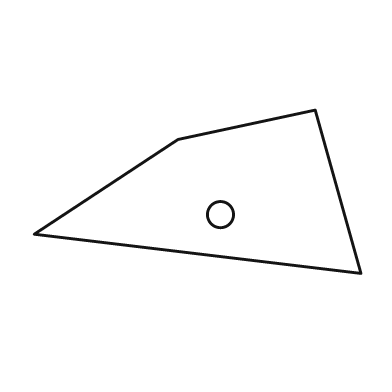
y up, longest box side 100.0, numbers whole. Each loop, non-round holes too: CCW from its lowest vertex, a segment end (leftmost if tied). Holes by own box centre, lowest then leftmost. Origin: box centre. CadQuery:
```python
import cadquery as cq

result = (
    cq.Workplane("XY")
    .moveTo(50.0, -25.0)
    .lineTo(36.0, 25.0)
    .lineTo(-6.0, 16.0)
    .lineTo(-50.0, -13.0)
    .close()
    .moveTo(7.0, -7.0)
    .circle(4.0)
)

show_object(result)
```